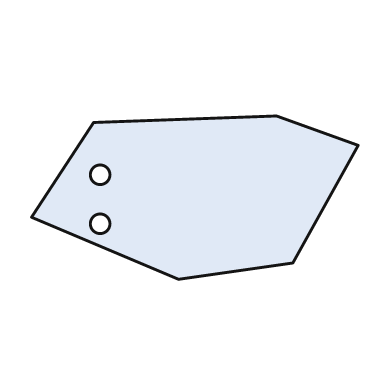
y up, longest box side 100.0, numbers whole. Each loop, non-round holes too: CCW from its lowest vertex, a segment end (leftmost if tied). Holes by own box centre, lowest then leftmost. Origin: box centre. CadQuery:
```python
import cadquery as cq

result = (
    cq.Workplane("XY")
    .moveTo(-5.0, -25.0)
    .lineTo(30.0, -20.0)
    .lineTo(50.0, 16.0)
    .lineTo(25.0, 25.0)
    .lineTo(-31.0, 23.0)
    .lineTo(-50.0, -6.0)
    .close()
    .moveTo(-29.0, -8.0)
    .circle(3.0)
    .moveTo(-29.0, 7.0)
    .circle(3.0)
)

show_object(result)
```